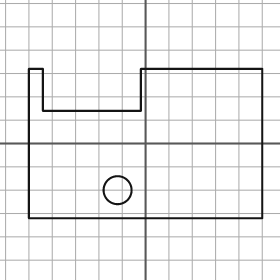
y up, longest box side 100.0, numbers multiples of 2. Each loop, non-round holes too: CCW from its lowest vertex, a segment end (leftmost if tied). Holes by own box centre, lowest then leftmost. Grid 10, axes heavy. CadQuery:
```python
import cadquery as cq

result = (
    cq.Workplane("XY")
    .moveTo(-50.0, -32.0)
    .lineTo(50.0, -32.0)
    .lineTo(50.0, 32.0)
    .lineTo(-2.0, 32.0)
    .lineTo(-2.0, 14.0)
    .lineTo(-44.0, 14.0)
    .lineTo(-44.0, 32.0)
    .lineTo(-50.0, 32.0)
    .close()
    .moveTo(-12.0, -20.0)
    .circle(6.0)
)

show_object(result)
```